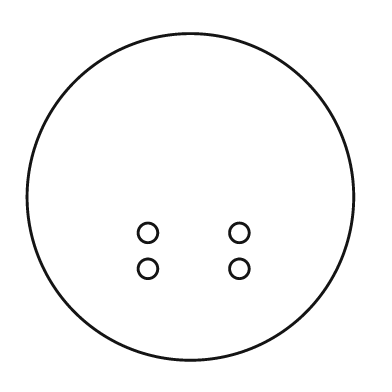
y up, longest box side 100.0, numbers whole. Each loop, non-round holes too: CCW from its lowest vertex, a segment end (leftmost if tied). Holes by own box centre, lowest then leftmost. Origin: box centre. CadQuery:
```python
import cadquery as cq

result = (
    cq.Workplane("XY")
    .moveTo(0.0, 0.0)
    .circle(50.0)
    .moveTo(-13.0, -22.0)
    .circle(3.0)
    .moveTo(15.0, -22.0)
    .circle(3.0)
    .moveTo(-13.0, -11.0)
    .circle(3.0)
    .moveTo(15.0, -11.0)
    .circle(3.0)
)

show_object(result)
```